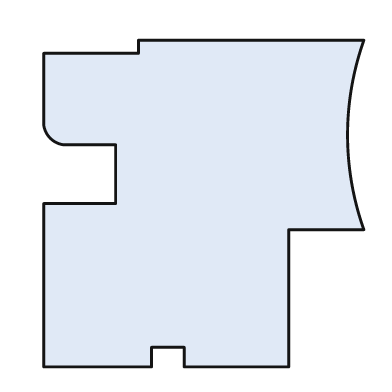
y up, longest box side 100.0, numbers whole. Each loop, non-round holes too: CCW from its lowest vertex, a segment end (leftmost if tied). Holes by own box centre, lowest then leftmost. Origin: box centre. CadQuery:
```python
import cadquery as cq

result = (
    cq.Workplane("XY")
    .moveTo(-49.0, -50.0)
    .lineTo(-16.0, -50.0)
    .lineTo(-16.0, -44.0)
    .lineTo(-6.0, -44.0)
    .lineTo(-6.0, -50.0)
    .lineTo(26.0, -50.0)
    .lineTo(26.0, -8.0)
    .lineTo(49.0, -8.0)
    .threePointArc((44.0, 21.0), (49.0, 50.0))
    .lineTo(-20.0, 50.0)
    .lineTo(-20.0, 46.0)
    .lineTo(-49.0, 46.0)
    .lineTo(-49.0, 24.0)
    .threePointArc((-47.0, 20.0), (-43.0, 18.0))
    .lineTo(-27.0, 18.0)
    .lineTo(-27.0, 0.0)
    .lineTo(-49.0, 0.0)
    .close()
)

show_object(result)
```